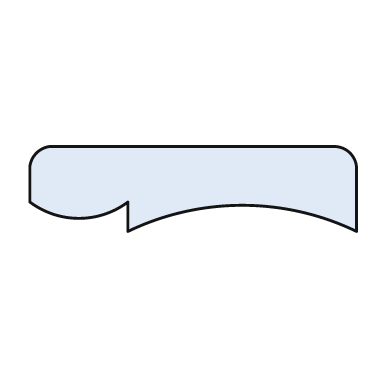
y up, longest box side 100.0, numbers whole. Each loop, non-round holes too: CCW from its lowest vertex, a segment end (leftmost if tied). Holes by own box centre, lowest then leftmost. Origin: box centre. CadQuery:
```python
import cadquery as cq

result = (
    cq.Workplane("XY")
    .moveTo(-20.0, -13.0)
    .threePointArc((15.0, -5.0), (50.0, -13.0))
    .lineTo(50.0, 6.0)
    .threePointArc((48.0, 11.0), (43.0, 13.0))
    .lineTo(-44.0, 13.0)
    .threePointArc((-48.0, 11.0), (-50.0, 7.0))
    .lineTo(-50.0, -4.0)
    .threePointArc((-35.0, -9.0), (-20.0, -4.0))
    .close()
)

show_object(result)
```